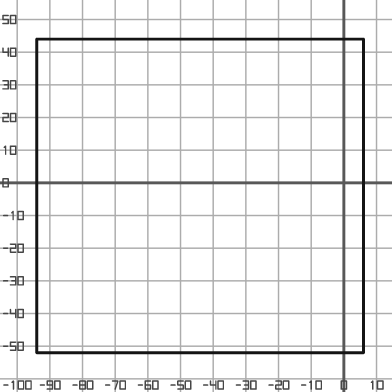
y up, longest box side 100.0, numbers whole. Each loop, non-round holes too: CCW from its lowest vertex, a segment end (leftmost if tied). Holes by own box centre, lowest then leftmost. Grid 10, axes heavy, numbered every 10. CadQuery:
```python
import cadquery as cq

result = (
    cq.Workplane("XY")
    .moveTo(-94.0, -52.0)
    .lineTo(6.0, -52.0)
    .lineTo(6.0, 44.0)
    .lineTo(-94.0, 44.0)
    .close()
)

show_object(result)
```